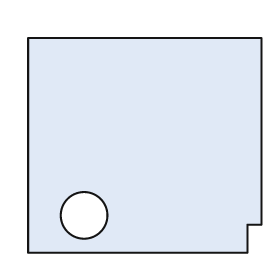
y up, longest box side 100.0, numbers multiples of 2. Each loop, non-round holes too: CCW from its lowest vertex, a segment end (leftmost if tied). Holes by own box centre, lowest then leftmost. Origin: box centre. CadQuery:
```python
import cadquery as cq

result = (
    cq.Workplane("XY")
    .moveTo(-50.0, -46.0)
    .lineTo(44.0, -46.0)
    .lineTo(44.0, -34.0)
    .lineTo(50.0, -34.0)
    .lineTo(50.0, 46.0)
    .lineTo(-50.0, 46.0)
    .close()
    .moveTo(-26.0, -30.0)
    .circle(10.0)
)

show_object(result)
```